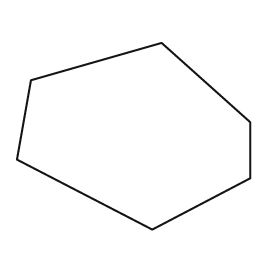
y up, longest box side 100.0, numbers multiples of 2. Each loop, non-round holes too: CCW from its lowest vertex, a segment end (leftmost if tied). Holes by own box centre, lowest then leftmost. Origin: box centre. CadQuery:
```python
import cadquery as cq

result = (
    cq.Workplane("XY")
    .moveTo(8.0, -40.0)
    .lineTo(50.0, -18.0)
    .lineTo(50.0, 6.0)
    .lineTo(12.0, 40.0)
    .lineTo(-44.0, 24.0)
    .lineTo(-50.0, -10.0)
    .close()
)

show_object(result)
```